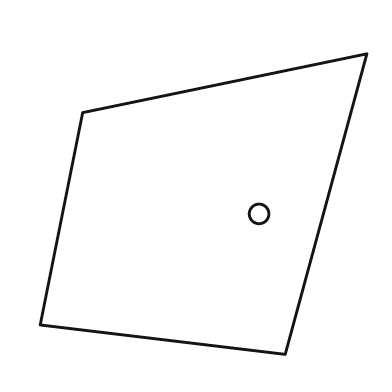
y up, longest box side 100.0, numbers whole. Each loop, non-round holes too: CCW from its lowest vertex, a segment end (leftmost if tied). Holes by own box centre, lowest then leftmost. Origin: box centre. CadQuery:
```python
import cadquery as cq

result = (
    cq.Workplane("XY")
    .moveTo(25.0, -46.0)
    .lineTo(50.0, 46.0)
    .lineTo(-37.0, 28.0)
    .lineTo(-50.0, -37.0)
    .close()
    .moveTo(17.0, -3.0)
    .circle(3.0)
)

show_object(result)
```